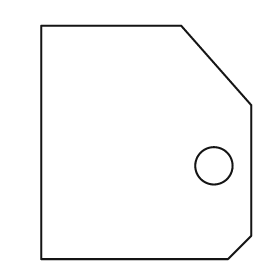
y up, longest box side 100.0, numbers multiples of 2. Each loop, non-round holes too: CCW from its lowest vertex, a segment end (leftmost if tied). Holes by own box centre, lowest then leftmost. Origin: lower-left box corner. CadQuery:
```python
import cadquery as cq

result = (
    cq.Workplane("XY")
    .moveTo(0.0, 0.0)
    .lineTo(80.0, 0.0)
    .lineTo(90.0, 10.0)
    .lineTo(90.0, 66.0)
    .lineTo(60.0, 100.0)
    .lineTo(0.0, 100.0)
    .close()
    .moveTo(74.0, 40.0)
    .circle(8.0)
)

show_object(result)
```